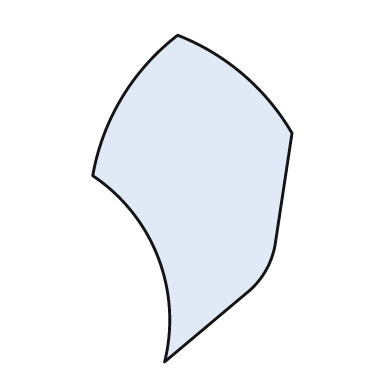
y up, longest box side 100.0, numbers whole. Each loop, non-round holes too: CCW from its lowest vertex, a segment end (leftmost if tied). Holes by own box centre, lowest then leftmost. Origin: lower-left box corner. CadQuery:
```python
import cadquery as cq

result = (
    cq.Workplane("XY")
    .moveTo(22.0, 0.0)
    .lineTo(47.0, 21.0)
    .threePointArc((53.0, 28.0), (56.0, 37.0))
    .lineTo(61.0, 70.0)
    .threePointArc((46.0, 88.0), (26.0, 100.0))
    .threePointArc((9.0, 81.0), (0.0, 57.0))
    .threePointArc((20.0, 32.0), (22.0, 0.0))
    .close()
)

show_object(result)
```